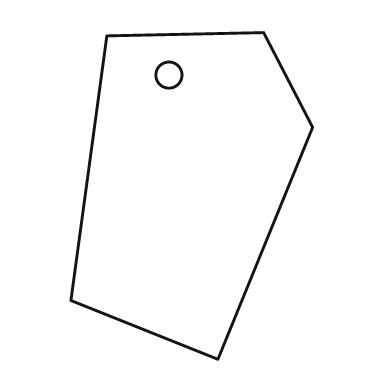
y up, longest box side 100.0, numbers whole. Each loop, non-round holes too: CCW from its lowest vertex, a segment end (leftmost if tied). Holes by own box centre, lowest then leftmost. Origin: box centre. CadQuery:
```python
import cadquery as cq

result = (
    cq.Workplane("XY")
    .moveTo(8.0, -50.0)
    .lineTo(37.0, 21.0)
    .lineTo(22.0, 50.0)
    .lineTo(-26.0, 49.0)
    .lineTo(-37.0, -32.0)
    .close()
    .moveTo(-7.0, 37.0)
    .circle(4.0)
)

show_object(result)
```